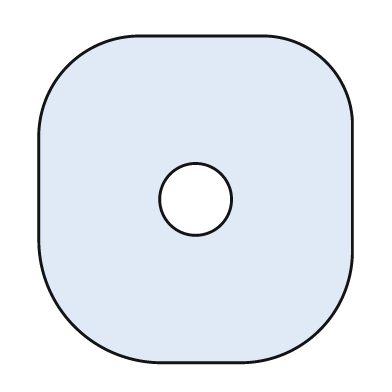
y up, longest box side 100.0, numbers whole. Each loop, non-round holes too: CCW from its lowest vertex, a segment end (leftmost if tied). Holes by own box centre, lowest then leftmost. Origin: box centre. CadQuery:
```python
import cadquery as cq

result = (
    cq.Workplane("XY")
    .moveTo(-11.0, -50.0)
    .lineTo(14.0, -50.0)
    .threePointArc((38.0, -40.0), (48.0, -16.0))
    .lineTo(48.0, 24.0)
    .threePointArc((40.0, 42.0), (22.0, 50.0))
    .lineTo(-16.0, 50.0)
    .threePointArc((-39.0, 41.0), (-48.0, 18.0))
    .lineTo(-48.0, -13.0)
    .threePointArc((-37.0, -39.0), (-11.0, -50.0))
    .close()
    .moveTo(0.0, 0.0)
    .circle(11.0)
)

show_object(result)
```